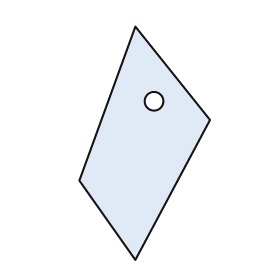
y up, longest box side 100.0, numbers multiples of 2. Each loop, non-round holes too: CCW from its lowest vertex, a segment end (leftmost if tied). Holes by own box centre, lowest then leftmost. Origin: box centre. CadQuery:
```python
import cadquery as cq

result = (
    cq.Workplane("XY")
    .moveTo(-4.0, -50.0)
    .lineTo(28.0, 10.0)
    .lineTo(-4.0, 50.0)
    .lineTo(-28.0, -16.0)
    .close()
    .moveTo(4.0, 18.0)
    .circle(4.0)
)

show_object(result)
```